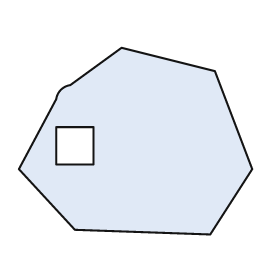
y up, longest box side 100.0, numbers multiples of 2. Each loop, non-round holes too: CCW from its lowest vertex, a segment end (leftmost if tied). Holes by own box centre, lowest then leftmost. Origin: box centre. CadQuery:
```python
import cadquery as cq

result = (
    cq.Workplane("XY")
    .moveTo(32.0, -40.0)
    .lineTo(50.0, -12.0)
    .lineTo(34.0, 30.0)
    .lineTo(-6.0, 40.0)
    .lineTo(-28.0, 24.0)
    .threePointArc((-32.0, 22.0), (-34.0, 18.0))
    .lineTo(-50.0, -12.0)
    .lineTo(-26.0, -38.0)
    .close()
    .moveTo(-34.0, -10.0)
    .lineTo(-18.0, -10.0)
    .lineTo(-18.0, 6.0)
    .lineTo(-34.0, 6.0)
    .close()
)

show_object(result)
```